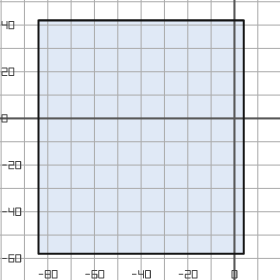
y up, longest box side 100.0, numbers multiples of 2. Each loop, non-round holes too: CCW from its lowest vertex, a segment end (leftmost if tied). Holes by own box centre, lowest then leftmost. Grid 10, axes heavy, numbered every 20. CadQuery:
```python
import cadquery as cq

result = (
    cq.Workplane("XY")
    .moveTo(-84.0, -58.0)
    .lineTo(4.0, -58.0)
    .lineTo(4.0, 42.0)
    .lineTo(-84.0, 42.0)
    .close()
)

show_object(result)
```